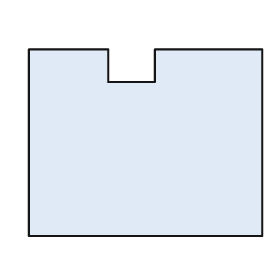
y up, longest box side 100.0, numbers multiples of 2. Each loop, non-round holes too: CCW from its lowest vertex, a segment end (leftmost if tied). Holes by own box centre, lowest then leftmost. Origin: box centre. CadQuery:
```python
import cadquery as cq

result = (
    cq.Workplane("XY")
    .moveTo(-50.0, -40.0)
    .lineTo(50.0, -40.0)
    .lineTo(50.0, 40.0)
    .lineTo(4.0, 40.0)
    .lineTo(4.0, 26.0)
    .lineTo(-16.0, 26.0)
    .lineTo(-16.0, 40.0)
    .lineTo(-50.0, 40.0)
    .close()
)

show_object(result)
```